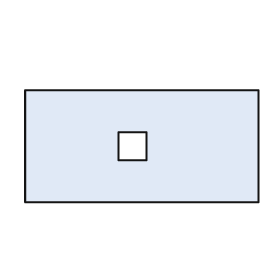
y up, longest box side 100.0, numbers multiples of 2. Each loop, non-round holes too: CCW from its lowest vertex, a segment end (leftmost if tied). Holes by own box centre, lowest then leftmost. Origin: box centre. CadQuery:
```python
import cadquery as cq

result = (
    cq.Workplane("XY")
    .moveTo(-50.0, -24.0)
    .lineTo(50.0, -24.0)
    .lineTo(50.0, 24.0)
    .lineTo(-50.0, 24.0)
    .close()
    .moveTo(-10.0, -6.0)
    .lineTo(2.0, -6.0)
    .lineTo(2.0, 6.0)
    .lineTo(-10.0, 6.0)
    .close()
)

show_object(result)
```